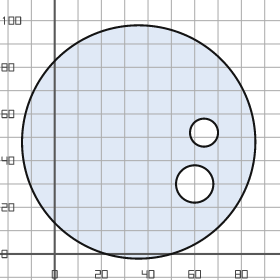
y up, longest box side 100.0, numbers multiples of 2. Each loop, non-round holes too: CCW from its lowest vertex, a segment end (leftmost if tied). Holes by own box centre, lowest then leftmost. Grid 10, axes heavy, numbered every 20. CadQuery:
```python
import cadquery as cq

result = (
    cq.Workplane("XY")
    .moveTo(36.0, 48.0)
    .circle(50.0)
    .moveTo(60.0, 30.0)
    .circle(8.0)
    .moveTo(64.0, 52.0)
    .circle(6.0)
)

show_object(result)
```